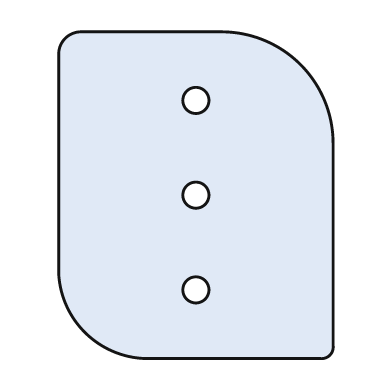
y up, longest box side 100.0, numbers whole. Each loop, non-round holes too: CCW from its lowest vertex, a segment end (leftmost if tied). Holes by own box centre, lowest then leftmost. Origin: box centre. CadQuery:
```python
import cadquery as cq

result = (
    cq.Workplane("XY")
    .moveTo(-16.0, -50.0)
    .lineTo(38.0, -50.0)
    .threePointArc((41.0, -49.0), (42.0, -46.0))
    .lineTo(42.0, 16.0)
    .threePointArc((32.0, 40.0), (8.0, 50.0))
    .lineTo(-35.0, 50.0)
    .threePointArc((-40.0, 48.0), (-42.0, 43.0))
    .lineTo(-42.0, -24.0)
    .threePointArc((-34.0, -42.0), (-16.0, -50.0))
    .close()
    .moveTo(0.0, -29.0)
    .circle(4.0)
    .moveTo(0.0, 0.0)
    .circle(4.0)
    .moveTo(0.0, 29.0)
    .circle(4.0)
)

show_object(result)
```